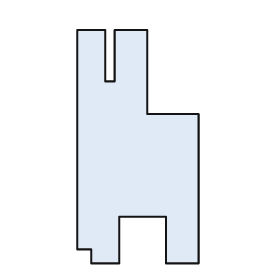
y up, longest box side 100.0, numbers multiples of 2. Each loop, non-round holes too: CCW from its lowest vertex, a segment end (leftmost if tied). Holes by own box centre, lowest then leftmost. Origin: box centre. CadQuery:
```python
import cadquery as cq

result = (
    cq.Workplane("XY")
    .moveTo(-20.0, -50.0)
    .lineTo(-8.0, -50.0)
    .lineTo(-8.0, -30.0)
    .lineTo(12.0, -30.0)
    .lineTo(12.0, -50.0)
    .lineTo(26.0, -50.0)
    .lineTo(26.0, 14.0)
    .lineTo(4.0, 14.0)
    .lineTo(4.0, 50.0)
    .lineTo(-10.0, 50.0)
    .lineTo(-10.0, 28.0)
    .lineTo(-14.0, 28.0)
    .lineTo(-14.0, 50.0)
    .lineTo(-26.0, 50.0)
    .lineTo(-26.0, -44.0)
    .lineTo(-20.0, -44.0)
    .close()
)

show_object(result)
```